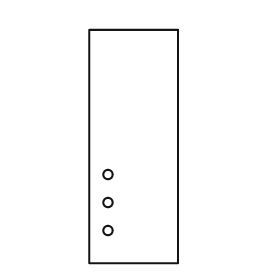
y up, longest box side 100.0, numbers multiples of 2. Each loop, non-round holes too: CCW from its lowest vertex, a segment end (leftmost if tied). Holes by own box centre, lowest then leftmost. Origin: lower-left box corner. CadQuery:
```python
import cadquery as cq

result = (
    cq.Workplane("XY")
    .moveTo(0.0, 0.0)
    .lineTo(38.0, 0.0)
    .lineTo(38.0, 100.0)
    .lineTo(0.0, 100.0)
    .close()
    .moveTo(8.0, 14.0)
    .circle(2.0)
    .moveTo(8.0, 26.0)
    .circle(2.0)
    .moveTo(8.0, 38.0)
    .circle(2.0)
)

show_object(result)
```